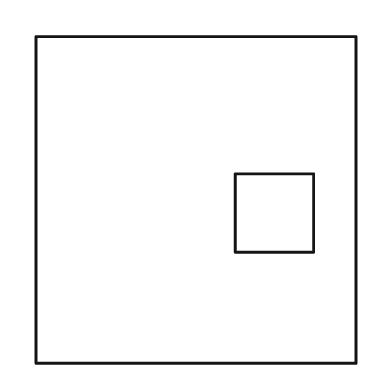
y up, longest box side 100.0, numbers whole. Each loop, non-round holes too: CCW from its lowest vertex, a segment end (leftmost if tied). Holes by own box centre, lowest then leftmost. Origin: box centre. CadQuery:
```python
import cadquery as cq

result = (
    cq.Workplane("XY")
    .moveTo(-49.0, -50.0)
    .lineTo(49.0, -50.0)
    .lineTo(49.0, 50.0)
    .lineTo(-49.0, 50.0)
    .close()
    .moveTo(12.0, -16.0)
    .lineTo(36.0, -16.0)
    .lineTo(36.0, 8.0)
    .lineTo(12.0, 8.0)
    .close()
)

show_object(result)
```